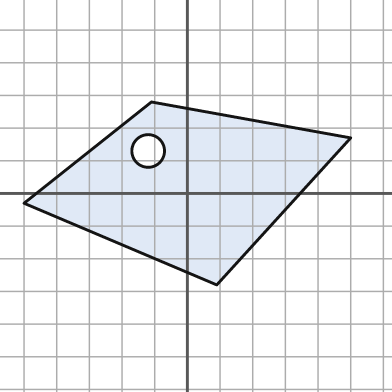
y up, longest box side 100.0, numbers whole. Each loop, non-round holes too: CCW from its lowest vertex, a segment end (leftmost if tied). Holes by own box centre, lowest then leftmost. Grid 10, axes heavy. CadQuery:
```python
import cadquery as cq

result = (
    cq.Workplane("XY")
    .moveTo(9.0, -28.0)
    .lineTo(50.0, 17.0)
    .lineTo(-11.0, 28.0)
    .lineTo(-50.0, -3.0)
    .close()
    .moveTo(-12.0, 13.0)
    .circle(5.0)
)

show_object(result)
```